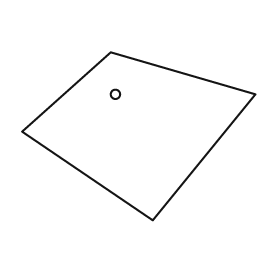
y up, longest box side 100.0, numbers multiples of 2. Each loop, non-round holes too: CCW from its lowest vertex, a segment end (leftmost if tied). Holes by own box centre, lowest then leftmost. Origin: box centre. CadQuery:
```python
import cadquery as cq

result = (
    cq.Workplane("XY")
    .moveTo(6.0, -36.0)
    .lineTo(50.0, 18.0)
    .lineTo(-12.0, 36.0)
    .lineTo(-50.0, 2.0)
    .close()
    .moveTo(-10.0, 18.0)
    .circle(2.0)
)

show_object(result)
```